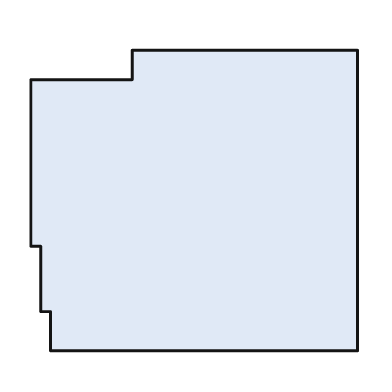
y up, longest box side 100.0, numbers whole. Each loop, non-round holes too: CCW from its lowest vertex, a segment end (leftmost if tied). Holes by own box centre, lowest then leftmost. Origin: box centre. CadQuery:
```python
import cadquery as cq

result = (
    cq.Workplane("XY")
    .moveTo(-44.0, -46.0)
    .lineTo(50.0, -46.0)
    .lineTo(50.0, 46.0)
    .lineTo(-19.0, 46.0)
    .lineTo(-19.0, 37.0)
    .lineTo(-50.0, 37.0)
    .lineTo(-50.0, -14.0)
    .lineTo(-47.0, -14.0)
    .lineTo(-47.0, -34.0)
    .lineTo(-44.0, -34.0)
    .close()
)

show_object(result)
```